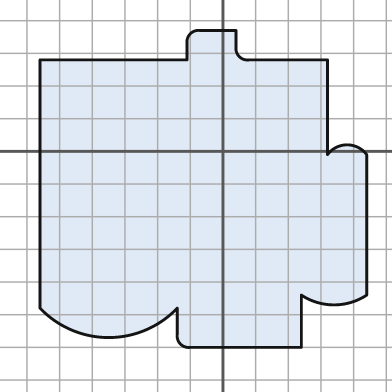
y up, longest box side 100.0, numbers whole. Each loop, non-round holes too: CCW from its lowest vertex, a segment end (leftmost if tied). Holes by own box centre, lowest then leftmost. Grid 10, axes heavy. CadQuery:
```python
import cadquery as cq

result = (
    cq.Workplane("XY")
    .moveTo(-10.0, -60.0)
    .lineTo(24.0, -60.0)
    .lineTo(24.0, -44.0)
    .threePointArc((34.0, -47.0), (44.0, -44.0))
    .lineTo(44.0, -1.0)
    .threePointArc((38.0, 2.0), (32.0, -1.0))
    .lineTo(32.0, 28.0)
    .lineTo(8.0, 28.0)
    .threePointArc((5.0, 29.0), (4.0, 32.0))
    .lineTo(4.0, 37.0)
    .lineTo(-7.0, 37.0)
    .threePointArc((-10.0, 36.0), (-11.0, 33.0))
    .lineTo(-11.0, 28.0)
    .lineTo(-56.0, 28.0)
    .lineTo(-56.0, -48.0)
    .threePointArc((-35.0, -57.0), (-14.0, -48.0))
    .lineTo(-14.0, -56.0)
    .threePointArc((-13.0, -59.0), (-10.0, -60.0))
    .close()
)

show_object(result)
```